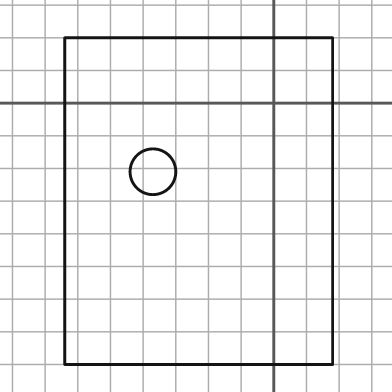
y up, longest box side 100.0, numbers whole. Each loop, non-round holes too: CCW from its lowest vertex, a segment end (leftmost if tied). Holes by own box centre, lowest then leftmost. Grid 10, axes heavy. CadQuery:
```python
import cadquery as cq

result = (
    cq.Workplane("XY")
    .moveTo(-64.0, -80.0)
    .lineTo(18.0, -80.0)
    .lineTo(18.0, 20.0)
    .lineTo(-64.0, 20.0)
    .close()
    .moveTo(-37.0, -21.0)
    .circle(7.0)
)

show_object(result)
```